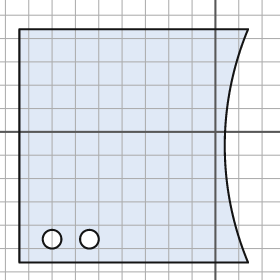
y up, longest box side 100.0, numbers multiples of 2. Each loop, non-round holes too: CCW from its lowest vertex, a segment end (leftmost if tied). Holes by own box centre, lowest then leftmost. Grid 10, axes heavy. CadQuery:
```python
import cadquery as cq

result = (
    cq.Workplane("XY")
    .moveTo(-84.0, -56.0)
    .lineTo(14.0, -56.0)
    .threePointArc((4.0, -6.0), (14.0, 44.0))
    .lineTo(-84.0, 44.0)
    .close()
    .moveTo(-70.0, -46.0)
    .circle(4.0)
    .moveTo(-54.0, -46.0)
    .circle(4.0)
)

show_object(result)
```